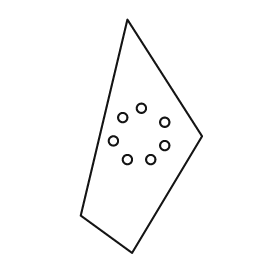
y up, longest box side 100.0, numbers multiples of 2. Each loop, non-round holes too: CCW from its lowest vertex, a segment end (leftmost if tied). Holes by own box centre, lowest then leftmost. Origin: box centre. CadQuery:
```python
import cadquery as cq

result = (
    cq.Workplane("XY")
    .moveTo(-4.0, -50.0)
    .lineTo(26.0, 0.0)
    .lineTo(-6.0, 50.0)
    .lineTo(-26.0, -34.0)
    .close()
    .moveTo(-6.0, -10.0)
    .circle(2.0)
    .moveTo(4.0, -10.0)
    .circle(2.0)
    .moveTo(10.0, -4.0)
    .circle(2.0)
    .moveTo(-12.0, -2.0)
    .circle(2.0)
    .moveTo(10.0, 6.0)
    .circle(2.0)
    .moveTo(-8.0, 8.0)
    .circle(2.0)
    .moveTo(0.0, 12.0)
    .circle(2.0)
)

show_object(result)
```